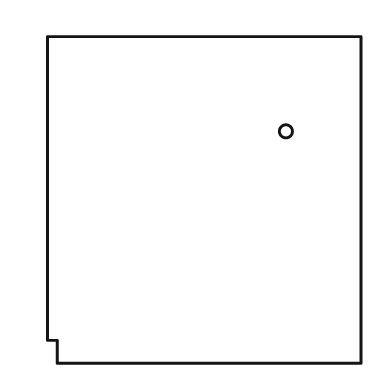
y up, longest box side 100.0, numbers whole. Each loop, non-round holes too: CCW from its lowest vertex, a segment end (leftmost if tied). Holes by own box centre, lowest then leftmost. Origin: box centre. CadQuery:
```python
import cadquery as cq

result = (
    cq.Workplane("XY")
    .moveTo(-45.0, -50.0)
    .lineTo(48.0, -50.0)
    .lineTo(48.0, 50.0)
    .lineTo(-48.0, 50.0)
    .lineTo(-48.0, -43.0)
    .lineTo(-45.0, -43.0)
    .close()
    .moveTo(25.0, 21.0)
    .circle(2.0)
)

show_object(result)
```